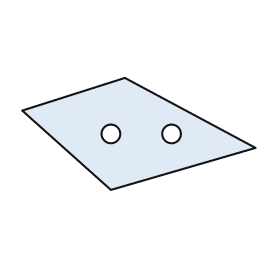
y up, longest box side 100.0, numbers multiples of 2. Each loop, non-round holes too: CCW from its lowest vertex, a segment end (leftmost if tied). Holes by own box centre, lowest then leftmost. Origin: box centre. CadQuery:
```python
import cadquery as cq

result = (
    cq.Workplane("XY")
    .moveTo(-12.0, -24.0)
    .lineTo(50.0, -6.0)
    .lineTo(-6.0, 24.0)
    .lineTo(-50.0, 10.0)
    .close()
    .moveTo(-12.0, 0.0)
    .circle(4.0)
    .moveTo(14.0, 0.0)
    .circle(4.0)
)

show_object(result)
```